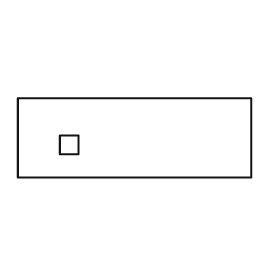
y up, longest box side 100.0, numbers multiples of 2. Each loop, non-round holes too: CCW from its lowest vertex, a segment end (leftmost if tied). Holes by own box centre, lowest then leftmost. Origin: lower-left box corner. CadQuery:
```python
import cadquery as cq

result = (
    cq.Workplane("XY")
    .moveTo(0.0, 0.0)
    .lineTo(100.0, 0.0)
    .lineTo(100.0, 34.0)
    .lineTo(0.0, 34.0)
    .close()
    .moveTo(18.0, 10.0)
    .lineTo(26.0, 10.0)
    .lineTo(26.0, 18.0)
    .lineTo(18.0, 18.0)
    .close()
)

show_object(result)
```